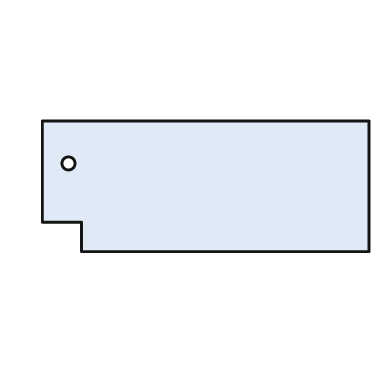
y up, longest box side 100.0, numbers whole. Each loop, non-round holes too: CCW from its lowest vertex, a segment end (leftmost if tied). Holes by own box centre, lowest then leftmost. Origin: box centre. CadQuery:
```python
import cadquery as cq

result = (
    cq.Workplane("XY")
    .moveTo(-38.0, -20.0)
    .lineTo(50.0, -20.0)
    .lineTo(50.0, 20.0)
    .lineTo(-50.0, 20.0)
    .lineTo(-50.0, -11.0)
    .lineTo(-38.0, -11.0)
    .close()
    .moveTo(-42.0, 7.0)
    .circle(2.0)
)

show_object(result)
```